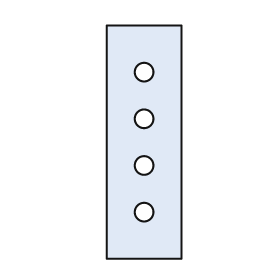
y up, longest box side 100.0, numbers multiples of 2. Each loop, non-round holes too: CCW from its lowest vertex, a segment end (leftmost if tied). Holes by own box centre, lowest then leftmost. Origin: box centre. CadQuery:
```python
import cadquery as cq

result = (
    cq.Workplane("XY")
    .moveTo(-16.0, -50.0)
    .lineTo(16.0, -50.0)
    .lineTo(16.0, 50.0)
    .lineTo(-16.0, 50.0)
    .close()
    .moveTo(0.0, -30.0)
    .circle(4.0)
    .moveTo(0.0, -10.0)
    .circle(4.0)
    .moveTo(0.0, 10.0)
    .circle(4.0)
    .moveTo(0.0, 30.0)
    .circle(4.0)
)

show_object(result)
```